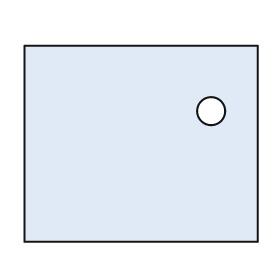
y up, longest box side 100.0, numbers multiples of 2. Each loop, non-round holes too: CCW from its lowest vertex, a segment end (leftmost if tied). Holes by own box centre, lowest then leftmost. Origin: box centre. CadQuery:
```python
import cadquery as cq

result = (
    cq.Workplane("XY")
    .moveTo(-50.0, -42.0)
    .lineTo(50.0, -42.0)
    .lineTo(50.0, 42.0)
    .lineTo(-50.0, 42.0)
    .close()
    .moveTo(30.0, 14.0)
    .circle(6.0)
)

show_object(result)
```